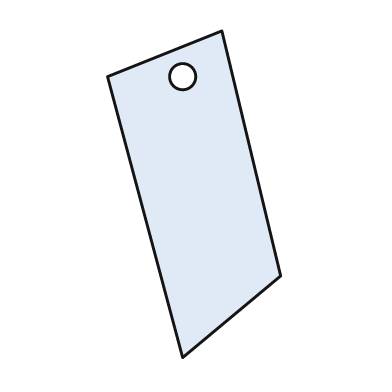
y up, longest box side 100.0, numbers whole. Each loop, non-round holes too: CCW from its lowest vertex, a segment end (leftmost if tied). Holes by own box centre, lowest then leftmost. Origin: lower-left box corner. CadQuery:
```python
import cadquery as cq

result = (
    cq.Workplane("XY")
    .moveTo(23.0, 0.0)
    .lineTo(53.0, 25.0)
    .lineTo(35.0, 100.0)
    .lineTo(0.0, 86.0)
    .close()
    .moveTo(23.0, 86.0)
    .circle(4.0)
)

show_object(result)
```